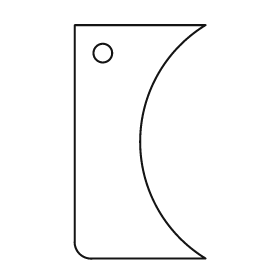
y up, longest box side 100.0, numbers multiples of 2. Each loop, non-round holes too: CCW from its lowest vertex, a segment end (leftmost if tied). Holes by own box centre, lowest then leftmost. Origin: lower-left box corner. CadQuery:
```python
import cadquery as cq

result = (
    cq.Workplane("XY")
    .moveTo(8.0, 0.0)
    .lineTo(56.0, 0.0)
    .threePointArc((28.0, 50.0), (56.0, 100.0))
    .lineTo(0.0, 100.0)
    .lineTo(0.0, 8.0)
    .threePointArc((2.0, 2.0), (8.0, 0.0))
    .close()
    .moveTo(12.0, 88.0)
    .circle(4.0)
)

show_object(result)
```